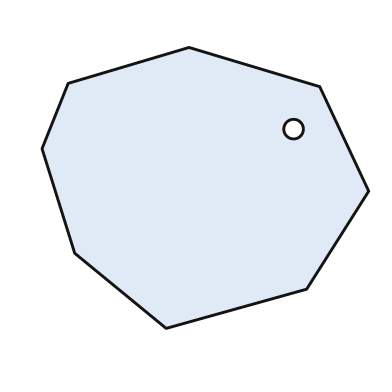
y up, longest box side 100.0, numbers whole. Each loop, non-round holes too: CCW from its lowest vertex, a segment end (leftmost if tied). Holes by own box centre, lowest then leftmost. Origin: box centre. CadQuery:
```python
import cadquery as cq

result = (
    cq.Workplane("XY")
    .moveTo(-12.0, -43.0)
    .lineTo(31.0, -31.0)
    .lineTo(50.0, -1.0)
    .lineTo(35.0, 31.0)
    .lineTo(-5.0, 43.0)
    .lineTo(-42.0, 32.0)
    .lineTo(-50.0, 12.0)
    .lineTo(-40.0, -20.0)
    .close()
    .moveTo(27.0, 18.0)
    .circle(3.0)
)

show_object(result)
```